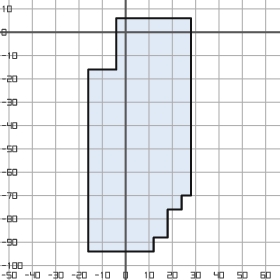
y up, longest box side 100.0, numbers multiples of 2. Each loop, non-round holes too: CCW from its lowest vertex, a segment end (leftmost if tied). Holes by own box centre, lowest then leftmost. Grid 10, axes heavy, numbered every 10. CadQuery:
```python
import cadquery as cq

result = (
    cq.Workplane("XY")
    .moveTo(-16.0, -94.0)
    .lineTo(12.0, -94.0)
    .lineTo(12.0, -88.0)
    .lineTo(18.0, -88.0)
    .lineTo(18.0, -76.0)
    .lineTo(24.0, -76.0)
    .lineTo(24.0, -70.0)
    .lineTo(28.0, -70.0)
    .lineTo(28.0, 6.0)
    .lineTo(-4.0, 6.0)
    .lineTo(-4.0, -16.0)
    .lineTo(-16.0, -16.0)
    .close()
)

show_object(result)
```